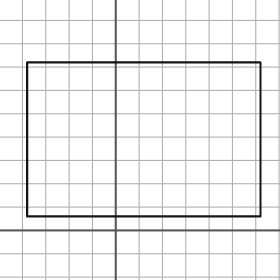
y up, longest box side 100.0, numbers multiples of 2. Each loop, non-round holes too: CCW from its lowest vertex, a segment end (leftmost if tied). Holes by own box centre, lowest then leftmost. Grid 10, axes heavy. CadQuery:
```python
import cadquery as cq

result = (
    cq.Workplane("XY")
    .moveTo(-38.0, 6.0)
    .lineTo(62.0, 6.0)
    .lineTo(62.0, 72.0)
    .lineTo(-38.0, 72.0)
    .close()
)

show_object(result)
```